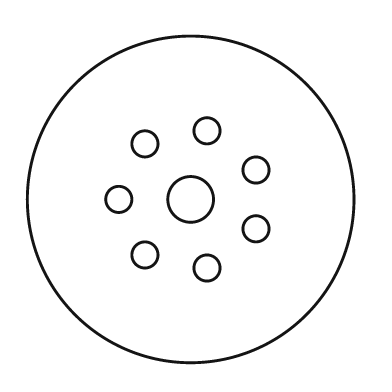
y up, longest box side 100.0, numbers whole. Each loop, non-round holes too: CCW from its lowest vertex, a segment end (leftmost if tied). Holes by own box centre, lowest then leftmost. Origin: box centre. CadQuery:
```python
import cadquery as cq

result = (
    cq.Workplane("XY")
    .moveTo(0.0, 0.0)
    .circle(50.0)
    .moveTo(5.0, -21.0)
    .circle(4.0)
    .moveTo(-14.0, -17.0)
    .circle(4.0)
    .moveTo(20.0, -9.0)
    .circle(4.0)
    .moveTo(-22.0, 0.0)
    .circle(4.0)
    .moveTo(0.0, 0.0)
    .circle(7.0)
    .moveTo(20.0, 9.0)
    .circle(4.0)
    .moveTo(-14.0, 17.0)
    .circle(4.0)
    .moveTo(5.0, 21.0)
    .circle(4.0)
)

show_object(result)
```